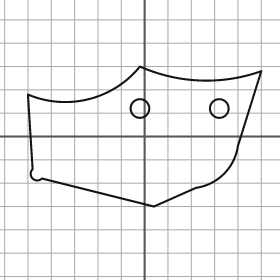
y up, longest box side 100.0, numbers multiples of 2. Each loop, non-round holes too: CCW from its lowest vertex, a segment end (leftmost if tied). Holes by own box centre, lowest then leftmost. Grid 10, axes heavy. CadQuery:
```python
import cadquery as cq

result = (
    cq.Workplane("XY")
    .moveTo(4.0, -30.0)
    .lineTo(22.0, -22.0)
    .threePointArc((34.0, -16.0), (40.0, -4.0))
    .lineTo(50.0, 28.0)
    .threePointArc((24.0, 24.0), (-2.0, 30.0))
    .threePointArc((-24.0, 16.0), (-50.0, 18.0))
    .lineTo(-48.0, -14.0)
    .threePointArc((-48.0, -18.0), (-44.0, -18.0))
    .close()
    .moveTo(-2.0, 12.0)
    .circle(4.0)
    .moveTo(32.0, 12.0)
    .circle(4.0)
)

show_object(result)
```